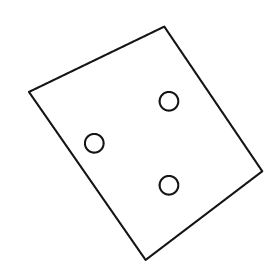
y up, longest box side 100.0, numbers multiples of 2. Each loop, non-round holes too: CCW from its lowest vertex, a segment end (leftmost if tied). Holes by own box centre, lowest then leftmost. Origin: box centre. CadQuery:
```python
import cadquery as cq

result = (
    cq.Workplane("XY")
    .moveTo(0.0, -50.0)
    .lineTo(50.0, -12.0)
    .lineTo(8.0, 50.0)
    .lineTo(-50.0, 22.0)
    .close()
    .moveTo(10.0, -18.0)
    .circle(4.0)
    .moveTo(-22.0, 0.0)
    .circle(4.0)
    .moveTo(10.0, 18.0)
    .circle(4.0)
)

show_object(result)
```